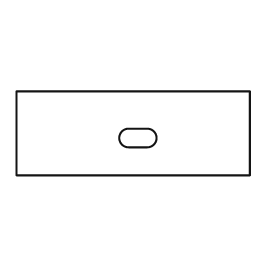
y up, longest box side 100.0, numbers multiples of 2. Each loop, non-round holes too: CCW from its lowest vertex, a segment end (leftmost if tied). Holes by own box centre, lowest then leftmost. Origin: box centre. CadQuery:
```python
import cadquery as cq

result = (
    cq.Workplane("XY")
    .moveTo(-50.0, -18.0)
    .lineTo(50.0, -18.0)
    .lineTo(50.0, 18.0)
    .lineTo(-50.0, 18.0)
    .close()
    .moveTo(-2.0, -6.0)
    .lineTo(6.0, -6.0)
    .threePointArc((10.0, -2.0), (6.0, 2.0))
    .lineTo(-2.0, 2.0)
    .threePointArc((-6.0, -2.0), (-2.0, -6.0))
    .close()
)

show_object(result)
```